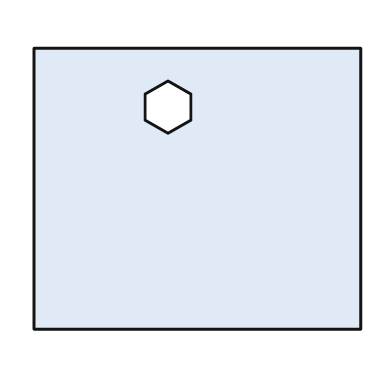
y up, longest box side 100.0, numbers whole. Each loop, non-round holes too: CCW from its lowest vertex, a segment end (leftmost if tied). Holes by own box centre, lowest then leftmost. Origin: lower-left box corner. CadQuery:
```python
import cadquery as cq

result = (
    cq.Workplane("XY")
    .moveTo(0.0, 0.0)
    .lineTo(100.0, 0.0)
    .lineTo(100.0, 86.0)
    .lineTo(0.0, 86.0)
    .close()
    .moveTo(41.0, 60.0)
    .lineTo(48.0, 64.0)
    .lineTo(48.0, 72.0)
    .lineTo(41.0, 76.0)
    .lineTo(34.0, 72.0)
    .lineTo(34.0, 64.0)
    .close()
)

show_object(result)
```